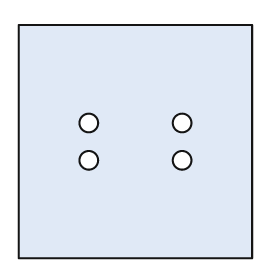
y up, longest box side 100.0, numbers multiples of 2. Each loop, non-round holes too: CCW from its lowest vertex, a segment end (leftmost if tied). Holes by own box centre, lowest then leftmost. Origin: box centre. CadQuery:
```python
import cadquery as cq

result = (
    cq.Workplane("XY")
    .moveTo(-50.0, -50.0)
    .lineTo(50.0, -50.0)
    .lineTo(50.0, 50.0)
    .lineTo(-50.0, 50.0)
    .close()
    .moveTo(-20.0, -8.0)
    .circle(4.0)
    .moveTo(20.0, -8.0)
    .circle(4.0)
    .moveTo(-20.0, 8.0)
    .circle(4.0)
    .moveTo(20.0, 8.0)
    .circle(4.0)
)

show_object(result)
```